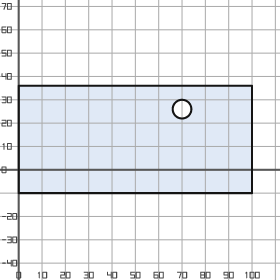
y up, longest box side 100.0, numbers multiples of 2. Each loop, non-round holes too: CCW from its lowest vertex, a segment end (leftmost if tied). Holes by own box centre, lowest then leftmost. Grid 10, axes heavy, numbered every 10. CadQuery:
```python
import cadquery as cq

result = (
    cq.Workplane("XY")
    .moveTo(0.0, -10.0)
    .lineTo(100.0, -10.0)
    .lineTo(100.0, 36.0)
    .lineTo(0.0, 36.0)
    .close()
    .moveTo(70.0, 26.0)
    .circle(4.0)
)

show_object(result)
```